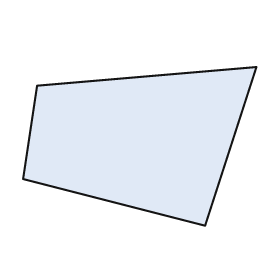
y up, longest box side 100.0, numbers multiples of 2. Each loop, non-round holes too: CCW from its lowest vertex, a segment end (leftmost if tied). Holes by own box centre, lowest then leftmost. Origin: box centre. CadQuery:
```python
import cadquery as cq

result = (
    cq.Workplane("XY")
    .moveTo(28.0, -34.0)
    .lineTo(50.0, 34.0)
    .lineTo(-44.0, 26.0)
    .lineTo(-50.0, -14.0)
    .close()
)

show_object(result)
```